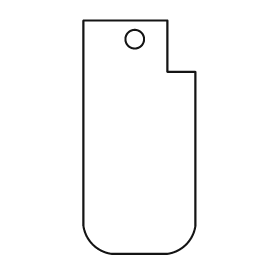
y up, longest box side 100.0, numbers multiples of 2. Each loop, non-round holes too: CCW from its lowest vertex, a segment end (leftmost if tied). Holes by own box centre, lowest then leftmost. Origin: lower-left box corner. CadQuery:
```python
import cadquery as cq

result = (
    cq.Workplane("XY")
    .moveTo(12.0, 0.0)
    .lineTo(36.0, 0.0)
    .threePointArc((44.0, 4.0), (48.0, 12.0))
    .lineTo(48.0, 78.0)
    .lineTo(36.0, 78.0)
    .lineTo(36.0, 100.0)
    .lineTo(0.0, 100.0)
    .lineTo(0.0, 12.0)
    .threePointArc((4.0, 4.0), (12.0, 0.0))
    .close()
    .moveTo(22.0, 92.0)
    .circle(4.0)
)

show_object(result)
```